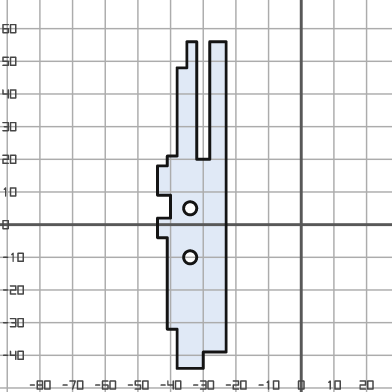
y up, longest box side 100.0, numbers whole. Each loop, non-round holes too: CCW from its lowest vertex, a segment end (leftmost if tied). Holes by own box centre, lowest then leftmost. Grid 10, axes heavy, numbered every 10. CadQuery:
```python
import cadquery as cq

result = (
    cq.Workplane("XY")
    .moveTo(-38.0, -44.0)
    .lineTo(-30.0, -44.0)
    .lineTo(-30.0, -39.0)
    .lineTo(-23.0, -39.0)
    .lineTo(-23.0, 56.0)
    .lineTo(-28.0, 56.0)
    .lineTo(-28.0, 20.0)
    .lineTo(-32.0, 20.0)
    .lineTo(-32.0, 56.0)
    .lineTo(-35.0, 56.0)
    .lineTo(-35.0, 48.0)
    .lineTo(-38.0, 48.0)
    .lineTo(-38.0, 21.0)
    .lineTo(-41.0, 21.0)
    .lineTo(-41.0, 18.0)
    .lineTo(-44.0, 18.0)
    .lineTo(-44.0, 9.0)
    .lineTo(-40.0, 9.0)
    .lineTo(-40.0, 2.0)
    .lineTo(-44.0, 2.0)
    .lineTo(-44.0, -4.0)
    .lineTo(-41.0, -4.0)
    .lineTo(-41.0, -32.0)
    .lineTo(-38.0, -32.0)
    .close()
    .moveTo(-34.0, -10.0)
    .circle(2.0)
    .moveTo(-34.0, 5.0)
    .circle(2.0)
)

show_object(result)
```